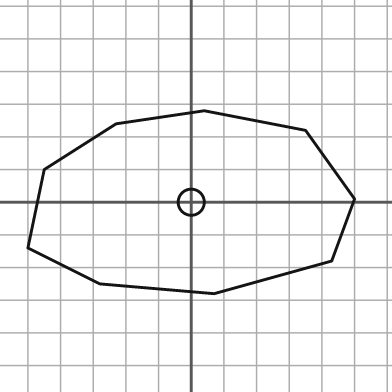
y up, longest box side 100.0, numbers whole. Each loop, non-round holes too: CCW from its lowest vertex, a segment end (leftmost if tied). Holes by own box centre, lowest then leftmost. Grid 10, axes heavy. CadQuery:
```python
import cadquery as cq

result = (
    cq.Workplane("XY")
    .moveTo(7.0, -28.0)
    .lineTo(43.0, -18.0)
    .lineTo(50.0, 1.0)
    .lineTo(35.0, 22.0)
    .lineTo(4.0, 28.0)
    .lineTo(-23.0, 24.0)
    .lineTo(-45.0, 10.0)
    .lineTo(-50.0, -14.0)
    .lineTo(-28.0, -25.0)
    .close()
    .moveTo(0.0, 0.0)
    .circle(4.0)
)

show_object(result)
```